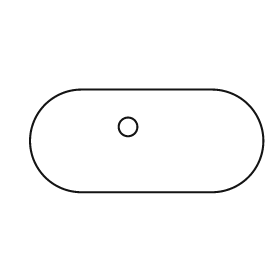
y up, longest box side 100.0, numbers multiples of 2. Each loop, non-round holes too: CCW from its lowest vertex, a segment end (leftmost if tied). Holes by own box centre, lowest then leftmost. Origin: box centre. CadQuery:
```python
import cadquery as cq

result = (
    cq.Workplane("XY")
    .moveTo(-28.0, -22.0)
    .lineTo(28.0, -22.0)
    .threePointArc((50.0, 0.0), (28.0, 22.0))
    .lineTo(-28.0, 22.0)
    .threePointArc((-50.0, 0.0), (-28.0, -22.0))
    .close()
    .moveTo(-8.0, 6.0)
    .circle(4.0)
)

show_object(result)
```